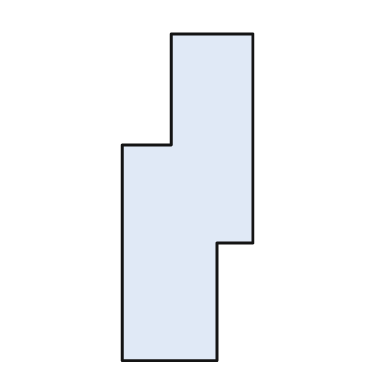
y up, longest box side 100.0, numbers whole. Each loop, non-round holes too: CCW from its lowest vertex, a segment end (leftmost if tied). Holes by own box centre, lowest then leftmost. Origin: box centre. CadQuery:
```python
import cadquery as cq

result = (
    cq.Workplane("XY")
    .moveTo(-20.0, -50.0)
    .lineTo(9.0, -50.0)
    .lineTo(9.0, -14.0)
    .lineTo(20.0, -14.0)
    .lineTo(20.0, 50.0)
    .lineTo(-5.0, 50.0)
    .lineTo(-5.0, 16.0)
    .lineTo(-20.0, 16.0)
    .close()
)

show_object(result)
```